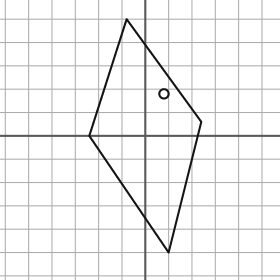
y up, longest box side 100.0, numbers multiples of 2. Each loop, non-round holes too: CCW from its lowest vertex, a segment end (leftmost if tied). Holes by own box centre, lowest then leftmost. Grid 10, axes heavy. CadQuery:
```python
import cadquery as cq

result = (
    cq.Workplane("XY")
    .moveTo(10.0, -50.0)
    .lineTo(24.0, 6.0)
    .lineTo(-8.0, 50.0)
    .lineTo(-24.0, 0.0)
    .close()
    .moveTo(8.0, 18.0)
    .circle(2.0)
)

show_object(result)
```